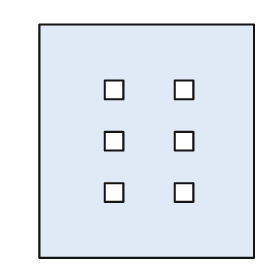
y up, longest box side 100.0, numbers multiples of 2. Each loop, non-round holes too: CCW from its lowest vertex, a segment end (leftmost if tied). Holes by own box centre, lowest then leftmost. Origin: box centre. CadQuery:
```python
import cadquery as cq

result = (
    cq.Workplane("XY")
    .moveTo(-46.0, -50.0)
    .lineTo(46.0, -50.0)
    .lineTo(46.0, 50.0)
    .lineTo(-46.0, 50.0)
    .close()
    .moveTo(-18.0, -26.0)
    .lineTo(-10.0, -26.0)
    .lineTo(-10.0, -18.0)
    .lineTo(-18.0, -18.0)
    .close()
    .moveTo(12.0, -26.0)
    .lineTo(20.0, -26.0)
    .lineTo(20.0, -18.0)
    .lineTo(12.0, -18.0)
    .close()
    .moveTo(-18.0, -4.0)
    .lineTo(-10.0, -4.0)
    .lineTo(-10.0, 4.0)
    .lineTo(-18.0, 4.0)
    .close()
    .moveTo(12.0, -4.0)
    .lineTo(20.0, -4.0)
    .lineTo(20.0, 4.0)
    .lineTo(12.0, 4.0)
    .close()
    .moveTo(-18.0, 18.0)
    .lineTo(-10.0, 18.0)
    .lineTo(-10.0, 26.0)
    .lineTo(-18.0, 26.0)
    .close()
    .moveTo(12.0, 18.0)
    .lineTo(20.0, 18.0)
    .lineTo(20.0, 26.0)
    .lineTo(12.0, 26.0)
    .close()
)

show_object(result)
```